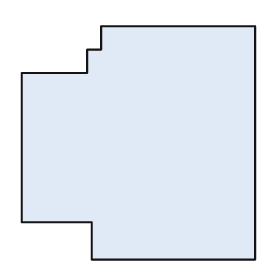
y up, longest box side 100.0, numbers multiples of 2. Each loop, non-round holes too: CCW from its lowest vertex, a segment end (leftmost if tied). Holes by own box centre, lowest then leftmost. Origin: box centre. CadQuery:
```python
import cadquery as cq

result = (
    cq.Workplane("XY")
    .moveTo(-20.0, -50.0)
    .lineTo(50.0, -50.0)
    .lineTo(50.0, 50.0)
    .lineTo(-16.0, 50.0)
    .lineTo(-16.0, 40.0)
    .lineTo(-22.0, 40.0)
    .lineTo(-22.0, 30.0)
    .lineTo(-50.0, 30.0)
    .lineTo(-50.0, -34.0)
    .lineTo(-20.0, -34.0)
    .close()
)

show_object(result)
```